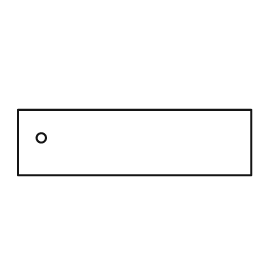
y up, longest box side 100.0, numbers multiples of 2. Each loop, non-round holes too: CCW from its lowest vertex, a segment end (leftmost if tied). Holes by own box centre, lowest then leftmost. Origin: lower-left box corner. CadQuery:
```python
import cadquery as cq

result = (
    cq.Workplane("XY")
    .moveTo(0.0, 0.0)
    .lineTo(100.0, 0.0)
    .lineTo(100.0, 28.0)
    .lineTo(0.0, 28.0)
    .close()
    .moveTo(10.0, 16.0)
    .circle(2.0)
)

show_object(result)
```